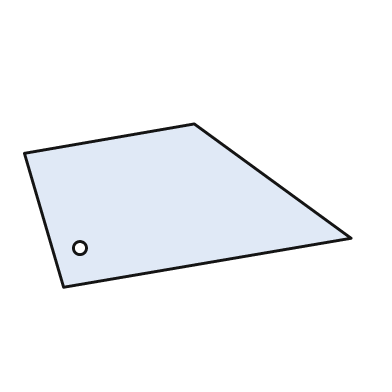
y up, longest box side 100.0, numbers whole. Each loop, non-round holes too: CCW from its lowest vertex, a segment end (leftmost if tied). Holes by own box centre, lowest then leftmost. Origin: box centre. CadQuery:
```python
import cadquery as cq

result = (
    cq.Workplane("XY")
    .moveTo(-38.0, -25.0)
    .lineTo(50.0, -10.0)
    .lineTo(2.0, 25.0)
    .lineTo(-50.0, 16.0)
    .close()
    .moveTo(-33.0, -13.0)
    .circle(2.0)
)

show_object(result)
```